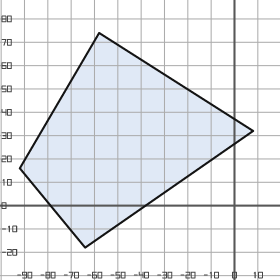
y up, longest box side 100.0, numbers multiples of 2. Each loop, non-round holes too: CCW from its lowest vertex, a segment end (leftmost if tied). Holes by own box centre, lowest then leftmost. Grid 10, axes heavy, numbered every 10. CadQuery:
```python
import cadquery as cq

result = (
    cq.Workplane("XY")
    .moveTo(-64.0, -18.0)
    .lineTo(8.0, 32.0)
    .lineTo(-58.0, 74.0)
    .lineTo(-92.0, 16.0)
    .close()
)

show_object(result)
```